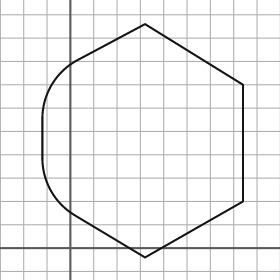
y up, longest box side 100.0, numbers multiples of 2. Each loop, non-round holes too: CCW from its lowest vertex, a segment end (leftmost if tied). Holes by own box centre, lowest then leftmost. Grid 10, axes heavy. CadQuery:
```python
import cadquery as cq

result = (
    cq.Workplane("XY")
    .moveTo(32.0, -4.0)
    .lineTo(74.0, 20.0)
    .lineTo(74.0, 70.0)
    .lineTo(32.0, 96.0)
    .lineTo(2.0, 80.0)
    .threePointArc((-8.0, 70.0), (-12.0, 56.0))
    .lineTo(-12.0, 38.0)
    .threePointArc((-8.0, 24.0), (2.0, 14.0))
    .close()
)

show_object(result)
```